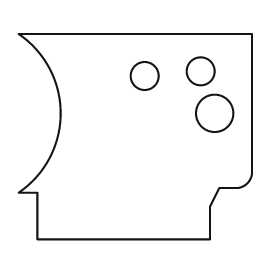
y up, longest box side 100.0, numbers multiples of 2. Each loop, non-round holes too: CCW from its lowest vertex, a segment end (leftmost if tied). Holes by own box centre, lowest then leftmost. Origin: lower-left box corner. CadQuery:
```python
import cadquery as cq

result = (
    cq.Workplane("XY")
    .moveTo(8.0, 0.0)
    .lineTo(82.0, 0.0)
    .lineTo(82.0, 14.0)
    .lineTo(86.0, 22.0)
    .lineTo(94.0, 22.0)
    .threePointArc((98.0, 24.0), (100.0, 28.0))
    .lineTo(100.0, 88.0)
    .lineTo(0.0, 88.0)
    .threePointArc((18.0, 54.0), (0.0, 20.0))
    .lineTo(8.0, 20.0)
    .close()
    .moveTo(84.0, 54.0)
    .circle(8.0)
    .moveTo(54.0, 70.0)
    .circle(6.0)
    .moveTo(78.0, 72.0)
    .circle(6.0)
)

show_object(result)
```